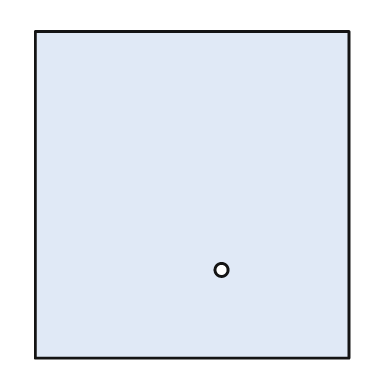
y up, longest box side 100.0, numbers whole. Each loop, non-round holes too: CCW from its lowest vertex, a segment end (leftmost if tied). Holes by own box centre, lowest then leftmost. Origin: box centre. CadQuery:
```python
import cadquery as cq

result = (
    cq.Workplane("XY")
    .moveTo(-48.0, -50.0)
    .lineTo(48.0, -50.0)
    .lineTo(48.0, 50.0)
    .lineTo(-48.0, 50.0)
    .close()
    .moveTo(9.0, -23.0)
    .circle(2.0)
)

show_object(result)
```